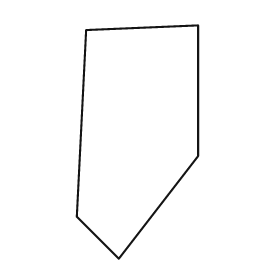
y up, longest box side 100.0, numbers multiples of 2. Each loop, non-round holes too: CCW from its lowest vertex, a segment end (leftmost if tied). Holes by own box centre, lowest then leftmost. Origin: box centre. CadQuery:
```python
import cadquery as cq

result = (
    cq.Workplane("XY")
    .moveTo(-8.0, -50.0)
    .lineTo(26.0, -6.0)
    .lineTo(26.0, 50.0)
    .lineTo(-22.0, 48.0)
    .lineTo(-26.0, -32.0)
    .close()
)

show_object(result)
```